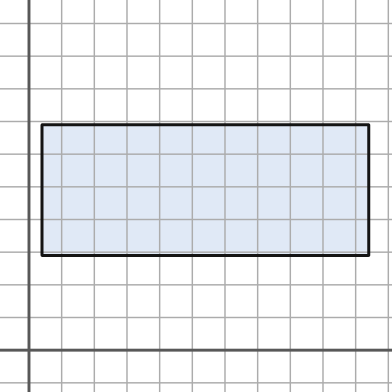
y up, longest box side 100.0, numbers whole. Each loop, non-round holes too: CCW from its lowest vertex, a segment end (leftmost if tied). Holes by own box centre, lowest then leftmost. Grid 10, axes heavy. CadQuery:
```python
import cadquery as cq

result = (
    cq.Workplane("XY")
    .moveTo(4.0, 29.0)
    .lineTo(104.0, 29.0)
    .lineTo(104.0, 69.0)
    .lineTo(4.0, 69.0)
    .close()
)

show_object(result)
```